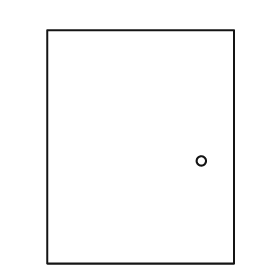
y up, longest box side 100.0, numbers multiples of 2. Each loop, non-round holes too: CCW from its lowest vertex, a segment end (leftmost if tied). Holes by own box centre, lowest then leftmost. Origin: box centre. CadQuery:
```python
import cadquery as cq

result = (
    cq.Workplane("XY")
    .moveTo(-40.0, -50.0)
    .lineTo(40.0, -50.0)
    .lineTo(40.0, 50.0)
    .lineTo(-40.0, 50.0)
    .close()
    .moveTo(26.0, -6.0)
    .circle(2.0)
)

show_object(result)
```